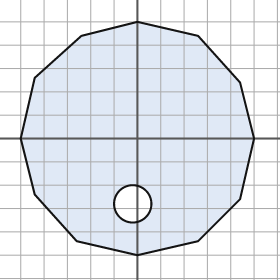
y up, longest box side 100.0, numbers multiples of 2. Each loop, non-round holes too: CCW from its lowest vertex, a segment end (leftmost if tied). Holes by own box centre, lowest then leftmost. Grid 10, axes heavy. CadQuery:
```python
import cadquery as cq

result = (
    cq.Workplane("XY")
    .moveTo(0.0, -50.0)
    .lineTo(26.0, -44.0)
    .lineTo(44.0, -26.0)
    .lineTo(50.0, 0.0)
    .lineTo(44.0, 24.0)
    .lineTo(26.0, 44.0)
    .lineTo(0.0, 50.0)
    .lineTo(-24.0, 44.0)
    .lineTo(-44.0, 26.0)
    .lineTo(-50.0, 0.0)
    .lineTo(-44.0, -24.0)
    .lineTo(-26.0, -44.0)
    .close()
    .moveTo(-2.0, -28.0)
    .circle(8.0)
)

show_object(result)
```